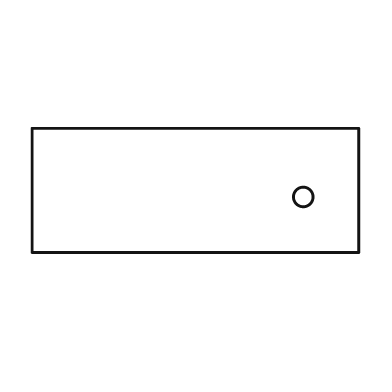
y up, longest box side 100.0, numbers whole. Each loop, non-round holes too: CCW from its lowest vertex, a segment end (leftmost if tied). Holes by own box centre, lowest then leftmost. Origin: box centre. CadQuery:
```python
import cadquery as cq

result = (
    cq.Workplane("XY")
    .moveTo(-50.0, -19.0)
    .lineTo(50.0, -19.0)
    .lineTo(50.0, 19.0)
    .lineTo(-50.0, 19.0)
    .close()
    .moveTo(33.0, -2.0)
    .circle(3.0)
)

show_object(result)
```